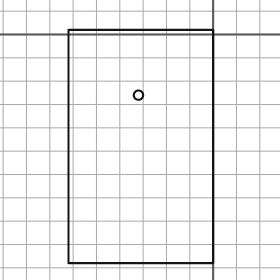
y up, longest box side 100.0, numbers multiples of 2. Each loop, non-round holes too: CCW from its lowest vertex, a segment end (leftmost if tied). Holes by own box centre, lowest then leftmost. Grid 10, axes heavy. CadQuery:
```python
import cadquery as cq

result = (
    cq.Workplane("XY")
    .moveTo(-62.0, -98.0)
    .lineTo(0.0, -98.0)
    .lineTo(0.0, 2.0)
    .lineTo(-62.0, 2.0)
    .close()
    .moveTo(-32.0, -26.0)
    .circle(2.0)
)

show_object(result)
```